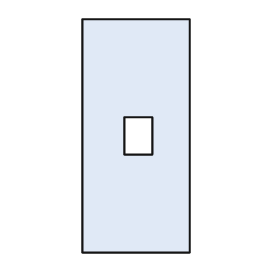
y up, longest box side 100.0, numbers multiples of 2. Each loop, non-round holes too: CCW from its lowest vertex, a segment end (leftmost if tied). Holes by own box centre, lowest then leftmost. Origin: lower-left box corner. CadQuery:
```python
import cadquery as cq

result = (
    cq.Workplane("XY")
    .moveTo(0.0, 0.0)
    .lineTo(46.0, 0.0)
    .lineTo(46.0, 100.0)
    .lineTo(0.0, 100.0)
    .close()
    .moveTo(18.0, 42.0)
    .lineTo(30.0, 42.0)
    .lineTo(30.0, 58.0)
    .lineTo(18.0, 58.0)
    .close()
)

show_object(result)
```